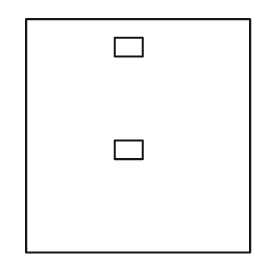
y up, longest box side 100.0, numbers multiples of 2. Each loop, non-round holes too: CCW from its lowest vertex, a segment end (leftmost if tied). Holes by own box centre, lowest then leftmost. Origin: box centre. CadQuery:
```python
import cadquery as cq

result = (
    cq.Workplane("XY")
    .moveTo(-48.0, -50.0)
    .lineTo(48.0, -50.0)
    .lineTo(48.0, 50.0)
    .lineTo(-48.0, 50.0)
    .close()
    .moveTo(-10.0, -10.0)
    .lineTo(2.0, -10.0)
    .lineTo(2.0, -2.0)
    .lineTo(-10.0, -2.0)
    .close()
    .moveTo(-10.0, 34.0)
    .lineTo(2.0, 34.0)
    .lineTo(2.0, 42.0)
    .lineTo(-10.0, 42.0)
    .close()
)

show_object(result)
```